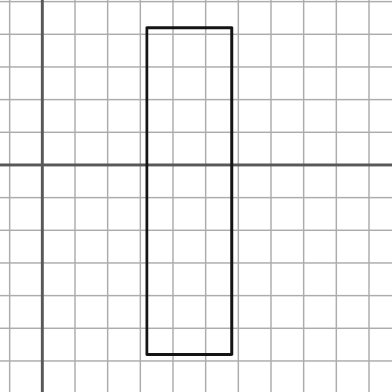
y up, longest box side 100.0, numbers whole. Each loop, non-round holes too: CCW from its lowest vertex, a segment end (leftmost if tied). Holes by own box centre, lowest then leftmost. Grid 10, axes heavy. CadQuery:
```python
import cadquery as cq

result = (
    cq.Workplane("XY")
    .moveTo(32.0, -58.0)
    .lineTo(58.0, -58.0)
    .lineTo(58.0, 42.0)
    .lineTo(32.0, 42.0)
    .close()
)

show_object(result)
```